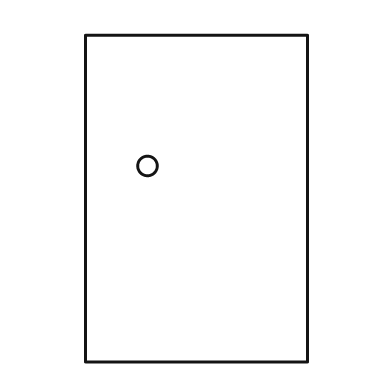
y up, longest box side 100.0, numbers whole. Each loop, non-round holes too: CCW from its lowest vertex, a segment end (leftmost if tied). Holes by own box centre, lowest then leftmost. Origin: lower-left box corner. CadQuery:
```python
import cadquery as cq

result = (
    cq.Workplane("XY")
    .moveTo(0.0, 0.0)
    .lineTo(68.0, 0.0)
    .lineTo(68.0, 100.0)
    .lineTo(0.0, 100.0)
    .close()
    .moveTo(19.0, 60.0)
    .circle(3.0)
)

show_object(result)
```